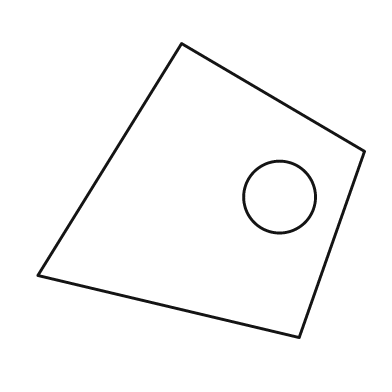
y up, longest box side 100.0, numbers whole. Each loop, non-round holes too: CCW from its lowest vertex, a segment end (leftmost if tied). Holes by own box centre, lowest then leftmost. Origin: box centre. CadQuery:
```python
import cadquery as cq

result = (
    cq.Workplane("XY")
    .moveTo(30.0, -45.0)
    .lineTo(50.0, 12.0)
    .lineTo(-6.0, 45.0)
    .lineTo(-50.0, -26.0)
    .close()
    .moveTo(24.0, -2.0)
    .circle(11.0)
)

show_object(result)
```